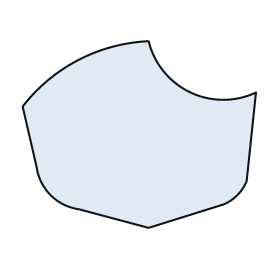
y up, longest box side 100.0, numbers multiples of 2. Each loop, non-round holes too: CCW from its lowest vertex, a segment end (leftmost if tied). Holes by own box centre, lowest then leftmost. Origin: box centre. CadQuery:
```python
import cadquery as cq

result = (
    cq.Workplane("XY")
    .moveTo(4.0, -40.0)
    .lineTo(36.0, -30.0)
    .threePointArc((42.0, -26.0), (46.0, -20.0))
    .lineTo(50.0, 18.0)
    .threePointArc((22.0, 18.0), (4.0, 40.0))
    .threePointArc((-26.0, 32.0), (-50.0, 12.0))
    .lineTo(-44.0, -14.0)
    .threePointArc((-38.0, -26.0), (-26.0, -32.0))
    .close()
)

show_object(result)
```